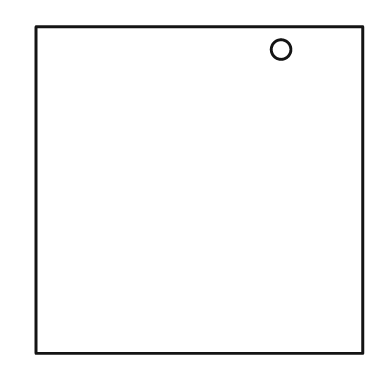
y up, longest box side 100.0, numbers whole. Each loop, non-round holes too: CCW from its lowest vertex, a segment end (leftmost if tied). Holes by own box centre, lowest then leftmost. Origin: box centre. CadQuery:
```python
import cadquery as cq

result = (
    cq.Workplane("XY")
    .moveTo(-50.0, -50.0)
    .lineTo(50.0, -50.0)
    .lineTo(50.0, 50.0)
    .lineTo(-50.0, 50.0)
    .close()
    .moveTo(25.0, 43.0)
    .circle(3.0)
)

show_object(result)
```